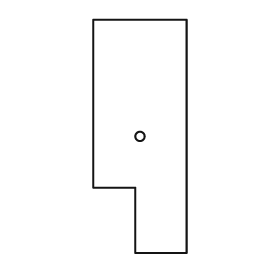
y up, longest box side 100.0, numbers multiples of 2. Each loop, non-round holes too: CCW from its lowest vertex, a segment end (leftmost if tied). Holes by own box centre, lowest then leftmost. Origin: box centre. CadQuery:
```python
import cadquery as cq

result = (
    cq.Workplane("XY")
    .moveTo(-2.0, -50.0)
    .lineTo(20.0, -50.0)
    .lineTo(20.0, 50.0)
    .lineTo(-20.0, 50.0)
    .lineTo(-20.0, -22.0)
    .lineTo(-2.0, -22.0)
    .close()
    .moveTo(0.0, 0.0)
    .circle(2.0)
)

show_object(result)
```